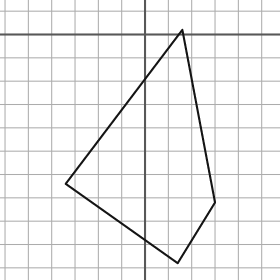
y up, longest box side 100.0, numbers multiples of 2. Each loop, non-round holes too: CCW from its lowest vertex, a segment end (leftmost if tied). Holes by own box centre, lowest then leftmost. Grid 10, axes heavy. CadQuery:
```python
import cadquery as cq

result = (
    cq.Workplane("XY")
    .moveTo(14.0, -98.0)
    .lineTo(30.0, -72.0)
    .lineTo(16.0, 2.0)
    .lineTo(-34.0, -64.0)
    .close()
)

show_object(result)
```